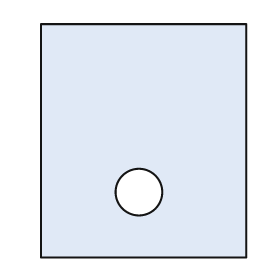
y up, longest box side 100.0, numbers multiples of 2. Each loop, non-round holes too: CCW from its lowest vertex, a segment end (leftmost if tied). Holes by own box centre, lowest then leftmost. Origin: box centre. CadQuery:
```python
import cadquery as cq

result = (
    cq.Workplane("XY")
    .moveTo(-44.0, -50.0)
    .lineTo(44.0, -50.0)
    .lineTo(44.0, 50.0)
    .lineTo(-44.0, 50.0)
    .close()
    .moveTo(-2.0, -22.0)
    .circle(10.0)
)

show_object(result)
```